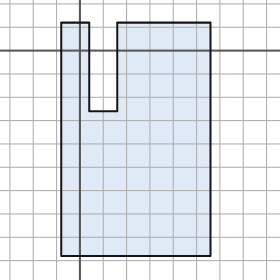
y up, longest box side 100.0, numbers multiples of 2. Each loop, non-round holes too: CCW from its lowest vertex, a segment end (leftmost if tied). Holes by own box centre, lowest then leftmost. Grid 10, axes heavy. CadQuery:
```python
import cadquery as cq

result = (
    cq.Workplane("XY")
    .moveTo(-8.0, -88.0)
    .lineTo(56.0, -88.0)
    .lineTo(56.0, 12.0)
    .lineTo(16.0, 12.0)
    .lineTo(16.0, -26.0)
    .lineTo(4.0, -26.0)
    .lineTo(4.0, 12.0)
    .lineTo(-8.0, 12.0)
    .close()
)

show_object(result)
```